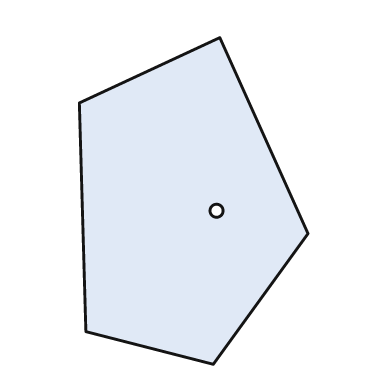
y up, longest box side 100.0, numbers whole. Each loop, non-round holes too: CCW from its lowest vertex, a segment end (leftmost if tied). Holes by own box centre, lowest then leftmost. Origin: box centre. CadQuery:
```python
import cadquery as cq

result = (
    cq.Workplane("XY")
    .moveTo(6.0, -50.0)
    .lineTo(35.0, -10.0)
    .lineTo(8.0, 50.0)
    .lineTo(-35.0, 30.0)
    .lineTo(-33.0, -40.0)
    .close()
    .moveTo(7.0, -3.0)
    .circle(2.0)
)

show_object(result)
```